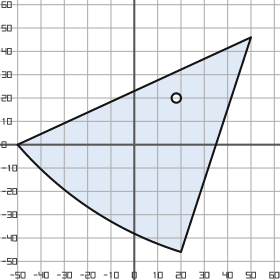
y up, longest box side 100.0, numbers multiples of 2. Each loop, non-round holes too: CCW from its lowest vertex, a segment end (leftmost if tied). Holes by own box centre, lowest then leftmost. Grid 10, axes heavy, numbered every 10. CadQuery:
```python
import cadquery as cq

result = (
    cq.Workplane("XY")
    .moveTo(20.0, -46.0)
    .lineTo(50.0, 46.0)
    .lineTo(-50.0, 0.0)
    .threePointArc((-18.0, -28.0), (20.0, -46.0))
    .close()
    .moveTo(18.0, 20.0)
    .circle(2.0)
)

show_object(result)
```